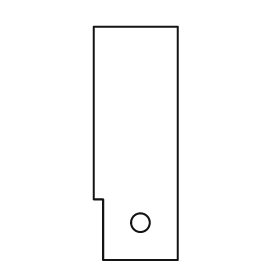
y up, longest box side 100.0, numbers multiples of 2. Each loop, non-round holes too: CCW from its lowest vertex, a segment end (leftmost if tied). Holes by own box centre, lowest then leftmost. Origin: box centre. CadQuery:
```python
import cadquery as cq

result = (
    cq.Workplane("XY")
    .moveTo(-14.0, -50.0)
    .lineTo(18.0, -50.0)
    .lineTo(18.0, 50.0)
    .lineTo(-18.0, 50.0)
    .lineTo(-18.0, -24.0)
    .lineTo(-14.0, -24.0)
    .close()
    .moveTo(2.0, -34.0)
    .circle(4.0)
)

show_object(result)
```